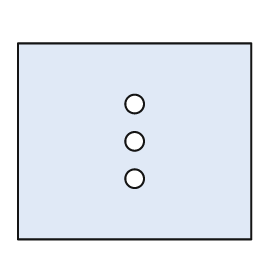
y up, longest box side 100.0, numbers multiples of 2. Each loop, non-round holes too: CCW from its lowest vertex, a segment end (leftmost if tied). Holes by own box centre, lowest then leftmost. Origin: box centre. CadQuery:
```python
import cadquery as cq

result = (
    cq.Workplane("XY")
    .moveTo(-50.0, -42.0)
    .lineTo(50.0, -42.0)
    .lineTo(50.0, 42.0)
    .lineTo(-50.0, 42.0)
    .close()
    .moveTo(0.0, -16.0)
    .circle(4.0)
    .moveTo(0.0, 0.0)
    .circle(4.0)
    .moveTo(0.0, 16.0)
    .circle(4.0)
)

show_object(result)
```